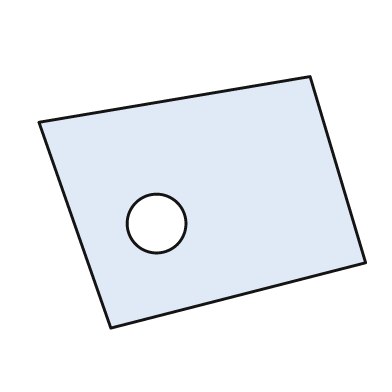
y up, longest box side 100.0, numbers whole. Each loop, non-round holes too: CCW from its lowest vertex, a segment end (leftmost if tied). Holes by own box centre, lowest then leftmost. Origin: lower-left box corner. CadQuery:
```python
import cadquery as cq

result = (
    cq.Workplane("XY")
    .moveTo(22.0, 0.0)
    .lineTo(100.0, 20.0)
    .lineTo(83.0, 77.0)
    .lineTo(0.0, 63.0)
    .close()
    .moveTo(36.0, 32.0)
    .circle(9.0)
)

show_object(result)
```